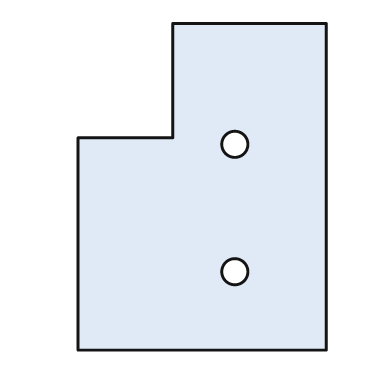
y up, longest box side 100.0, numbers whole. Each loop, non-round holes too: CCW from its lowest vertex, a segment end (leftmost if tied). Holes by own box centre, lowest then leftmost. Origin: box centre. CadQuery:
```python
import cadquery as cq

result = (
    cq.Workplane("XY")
    .moveTo(-38.0, -50.0)
    .lineTo(38.0, -50.0)
    .lineTo(38.0, 50.0)
    .lineTo(-9.0, 50.0)
    .lineTo(-9.0, 15.0)
    .lineTo(-38.0, 15.0)
    .close()
    .moveTo(10.0, -26.0)
    .circle(4.0)
    .moveTo(10.0, 13.0)
    .circle(4.0)
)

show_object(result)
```